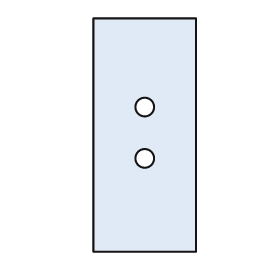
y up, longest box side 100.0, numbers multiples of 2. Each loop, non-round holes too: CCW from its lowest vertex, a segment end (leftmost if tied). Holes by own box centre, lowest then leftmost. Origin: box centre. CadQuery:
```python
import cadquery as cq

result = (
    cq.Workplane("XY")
    .moveTo(-22.0, -50.0)
    .lineTo(22.0, -50.0)
    .lineTo(22.0, 50.0)
    .lineTo(-22.0, 50.0)
    .close()
    .moveTo(0.0, -10.0)
    .circle(4.0)
    .moveTo(0.0, 12.0)
    .circle(4.0)
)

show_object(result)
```